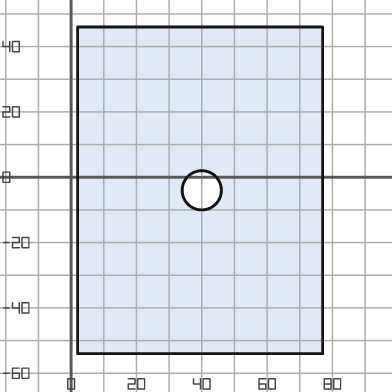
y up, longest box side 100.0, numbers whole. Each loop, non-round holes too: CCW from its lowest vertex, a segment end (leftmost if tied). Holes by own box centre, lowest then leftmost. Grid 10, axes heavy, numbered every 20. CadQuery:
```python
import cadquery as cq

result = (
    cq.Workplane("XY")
    .moveTo(2.0, -54.0)
    .lineTo(77.0, -54.0)
    .lineTo(77.0, 46.0)
    .lineTo(2.0, 46.0)
    .close()
    .moveTo(40.0, -4.0)
    .circle(6.0)
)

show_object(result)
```